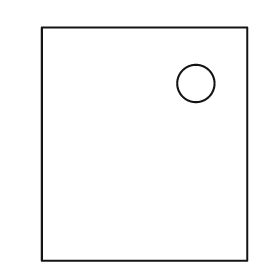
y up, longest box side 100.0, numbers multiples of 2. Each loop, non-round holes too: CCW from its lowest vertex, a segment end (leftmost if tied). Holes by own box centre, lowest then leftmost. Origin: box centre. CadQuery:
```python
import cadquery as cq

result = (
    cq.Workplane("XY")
    .moveTo(-44.0, -50.0)
    .lineTo(44.0, -50.0)
    .lineTo(44.0, 50.0)
    .lineTo(-44.0, 50.0)
    .close()
    .moveTo(22.0, 26.0)
    .circle(8.0)
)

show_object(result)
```